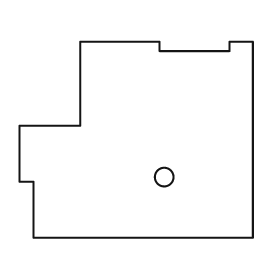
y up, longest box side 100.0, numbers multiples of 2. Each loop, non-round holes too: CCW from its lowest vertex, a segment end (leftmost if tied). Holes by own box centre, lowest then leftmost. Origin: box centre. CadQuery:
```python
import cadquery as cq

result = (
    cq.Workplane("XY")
    .moveTo(-44.0, -42.0)
    .lineTo(50.0, -42.0)
    .lineTo(50.0, 42.0)
    .lineTo(40.0, 42.0)
    .lineTo(40.0, 38.0)
    .lineTo(10.0, 38.0)
    .lineTo(10.0, 42.0)
    .lineTo(-24.0, 42.0)
    .lineTo(-24.0, 6.0)
    .lineTo(-50.0, 6.0)
    .lineTo(-50.0, -18.0)
    .lineTo(-44.0, -18.0)
    .close()
    .moveTo(12.0, -16.0)
    .circle(4.0)
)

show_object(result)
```